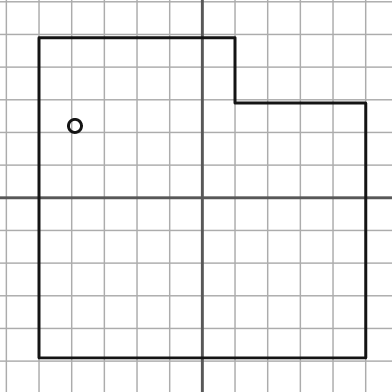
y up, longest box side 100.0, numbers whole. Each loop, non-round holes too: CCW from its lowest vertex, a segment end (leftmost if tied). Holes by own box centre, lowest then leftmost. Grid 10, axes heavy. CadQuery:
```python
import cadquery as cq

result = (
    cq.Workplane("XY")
    .moveTo(-50.0, -49.0)
    .lineTo(50.0, -49.0)
    .lineTo(50.0, 29.0)
    .lineTo(10.0, 29.0)
    .lineTo(10.0, 49.0)
    .lineTo(-50.0, 49.0)
    .close()
    .moveTo(-39.0, 22.0)
    .circle(2.0)
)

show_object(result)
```